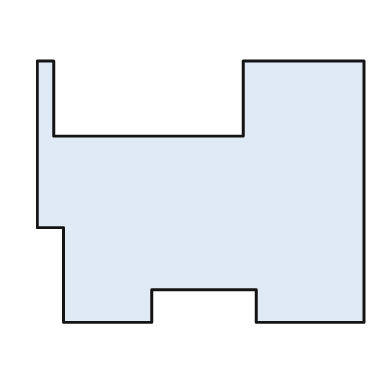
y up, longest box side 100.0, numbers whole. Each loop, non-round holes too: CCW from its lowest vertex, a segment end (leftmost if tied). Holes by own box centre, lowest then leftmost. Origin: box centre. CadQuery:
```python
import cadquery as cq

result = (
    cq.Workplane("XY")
    .moveTo(-42.0, -40.0)
    .lineTo(-15.0, -40.0)
    .lineTo(-15.0, -30.0)
    .lineTo(17.0, -30.0)
    .lineTo(17.0, -40.0)
    .lineTo(50.0, -40.0)
    .lineTo(50.0, 40.0)
    .lineTo(13.0, 40.0)
    .lineTo(13.0, 17.0)
    .lineTo(-45.0, 17.0)
    .lineTo(-45.0, 40.0)
    .lineTo(-50.0, 40.0)
    .lineTo(-50.0, -11.0)
    .lineTo(-42.0, -11.0)
    .close()
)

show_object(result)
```